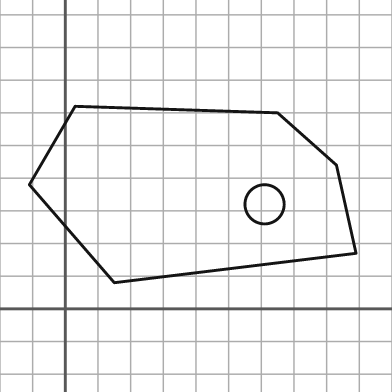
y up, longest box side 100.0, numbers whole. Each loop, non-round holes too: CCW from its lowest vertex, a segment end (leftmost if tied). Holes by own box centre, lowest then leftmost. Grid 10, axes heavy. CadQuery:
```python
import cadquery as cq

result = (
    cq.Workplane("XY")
    .moveTo(15.0, 8.0)
    .lineTo(89.0, 17.0)
    .lineTo(83.0, 44.0)
    .lineTo(65.0, 60.0)
    .lineTo(3.0, 62.0)
    .lineTo(-11.0, 38.0)
    .close()
    .moveTo(61.0, 32.0)
    .circle(6.0)
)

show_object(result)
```